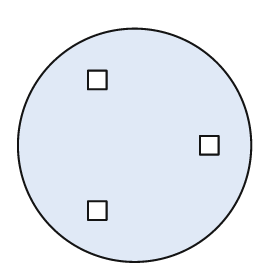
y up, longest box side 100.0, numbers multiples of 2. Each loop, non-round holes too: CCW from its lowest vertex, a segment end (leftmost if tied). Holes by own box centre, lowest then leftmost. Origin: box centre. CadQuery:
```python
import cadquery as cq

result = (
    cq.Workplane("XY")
    .moveTo(0.0, 0.0)
    .circle(50.0)
    .moveTo(-20.0, -32.0)
    .lineTo(-12.0, -32.0)
    .lineTo(-12.0, -24.0)
    .lineTo(-20.0, -24.0)
    .close()
    .moveTo(28.0, -4.0)
    .lineTo(36.0, -4.0)
    .lineTo(36.0, 4.0)
    .lineTo(28.0, 4.0)
    .close()
    .moveTo(-20.0, 24.0)
    .lineTo(-12.0, 24.0)
    .lineTo(-12.0, 32.0)
    .lineTo(-20.0, 32.0)
    .close()
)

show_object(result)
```